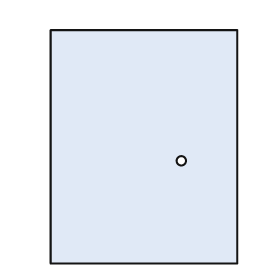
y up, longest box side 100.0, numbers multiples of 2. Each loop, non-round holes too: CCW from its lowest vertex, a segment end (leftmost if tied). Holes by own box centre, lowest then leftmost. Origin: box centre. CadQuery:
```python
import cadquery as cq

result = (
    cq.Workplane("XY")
    .moveTo(-40.0, -50.0)
    .lineTo(40.0, -50.0)
    .lineTo(40.0, 50.0)
    .lineTo(-40.0, 50.0)
    .close()
    .moveTo(16.0, -6.0)
    .circle(2.0)
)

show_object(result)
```